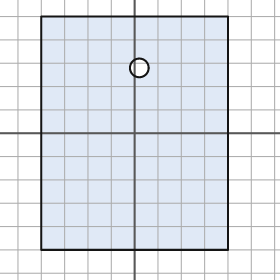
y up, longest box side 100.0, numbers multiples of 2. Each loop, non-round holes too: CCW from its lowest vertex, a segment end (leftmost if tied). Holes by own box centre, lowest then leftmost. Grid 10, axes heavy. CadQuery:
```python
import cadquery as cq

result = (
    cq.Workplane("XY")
    .moveTo(-40.0, -50.0)
    .lineTo(40.0, -50.0)
    .lineTo(40.0, 50.0)
    .lineTo(-40.0, 50.0)
    .close()
    .moveTo(2.0, 28.0)
    .circle(4.0)
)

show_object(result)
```